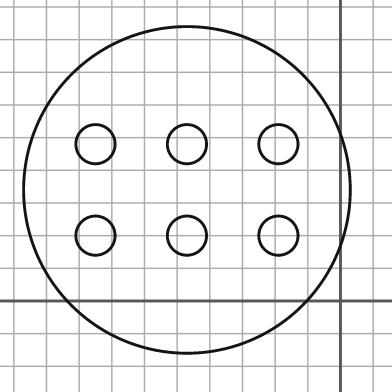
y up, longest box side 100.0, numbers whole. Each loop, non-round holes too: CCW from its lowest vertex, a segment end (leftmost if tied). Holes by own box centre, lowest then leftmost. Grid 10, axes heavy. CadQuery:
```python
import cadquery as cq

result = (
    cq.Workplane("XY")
    .moveTo(-47.0, 34.0)
    .circle(50.0)
    .moveTo(-75.0, 20.0)
    .circle(6.0)
    .moveTo(-47.0, 20.0)
    .circle(6.0)
    .moveTo(-19.0, 20.0)
    .circle(6.0)
    .moveTo(-75.0, 48.0)
    .circle(6.0)
    .moveTo(-47.0, 48.0)
    .circle(6.0)
    .moveTo(-19.0, 48.0)
    .circle(6.0)
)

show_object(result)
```